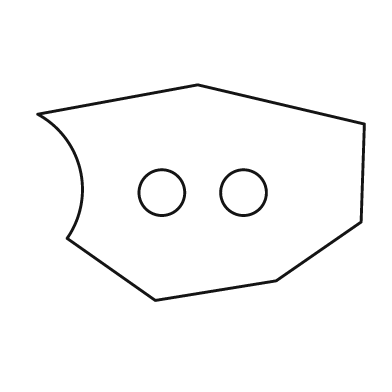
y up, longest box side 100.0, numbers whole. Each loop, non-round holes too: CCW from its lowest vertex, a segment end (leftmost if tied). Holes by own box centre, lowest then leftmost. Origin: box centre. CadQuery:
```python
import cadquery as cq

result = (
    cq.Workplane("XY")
    .moveTo(-14.0, -33.0)
    .lineTo(23.0, -27.0)
    .lineTo(49.0, -9.0)
    .lineTo(50.0, 21.0)
    .lineTo(-1.0, 33.0)
    .lineTo(-50.0, 24.0)
    .threePointArc((-37.0, 7.0), (-41.0, -14.0))
    .close()
    .moveTo(-12.0, 0.0)
    .circle(7.0)
    .moveTo(13.0, 0.0)
    .circle(7.0)
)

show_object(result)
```